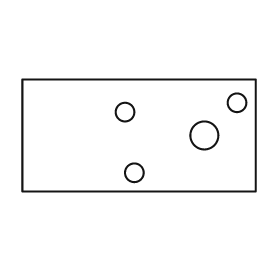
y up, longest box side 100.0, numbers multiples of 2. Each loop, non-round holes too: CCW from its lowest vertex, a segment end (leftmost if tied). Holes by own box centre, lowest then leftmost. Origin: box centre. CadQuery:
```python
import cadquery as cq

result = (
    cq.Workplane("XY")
    .moveTo(-50.0, -24.0)
    .lineTo(50.0, -24.0)
    .lineTo(50.0, 24.0)
    .lineTo(-50.0, 24.0)
    .close()
    .moveTo(-2.0, -16.0)
    .circle(4.0)
    .moveTo(28.0, 0.0)
    .circle(6.0)
    .moveTo(-6.0, 10.0)
    .circle(4.0)
    .moveTo(42.0, 14.0)
    .circle(4.0)
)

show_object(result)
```